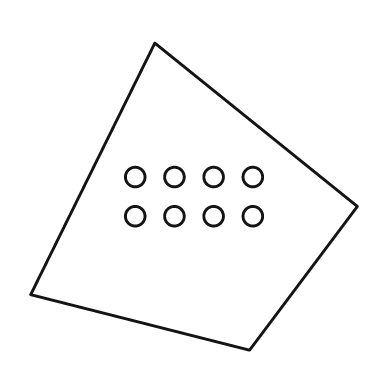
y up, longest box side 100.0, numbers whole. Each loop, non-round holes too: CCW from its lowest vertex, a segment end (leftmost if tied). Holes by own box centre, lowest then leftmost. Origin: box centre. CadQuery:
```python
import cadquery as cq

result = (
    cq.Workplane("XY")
    .moveTo(17.0, -47.0)
    .lineTo(50.0, -3.0)
    .lineTo(-12.0, 47.0)
    .lineTo(-50.0, -30.0)
    .close()
    .moveTo(-18.0, -6.0)
    .circle(3.0)
    .moveTo(-6.0, -6.0)
    .circle(3.0)
    .moveTo(6.0, -6.0)
    .circle(3.0)
    .moveTo(18.0, -6.0)
    .circle(3.0)
    .moveTo(-18.0, 6.0)
    .circle(3.0)
    .moveTo(-6.0, 6.0)
    .circle(3.0)
    .moveTo(6.0, 6.0)
    .circle(3.0)
    .moveTo(18.0, 6.0)
    .circle(3.0)
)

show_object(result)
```